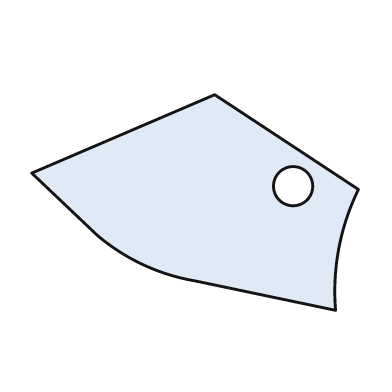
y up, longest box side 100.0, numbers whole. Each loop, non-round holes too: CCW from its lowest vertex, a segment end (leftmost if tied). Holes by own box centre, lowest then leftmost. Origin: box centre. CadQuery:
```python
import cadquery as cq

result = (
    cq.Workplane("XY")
    .moveTo(43.0, -33.0)
    .threePointArc((44.0, -14.0), (50.0, 4.0))
    .lineTo(6.0, 33.0)
    .lineTo(-50.0, 9.0)
    .lineTo(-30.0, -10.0)
    .threePointArc((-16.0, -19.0), (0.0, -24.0))
    .close()
    .moveTo(30.0, 5.0)
    .circle(6.0)
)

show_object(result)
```